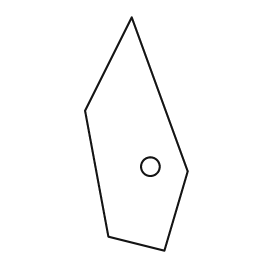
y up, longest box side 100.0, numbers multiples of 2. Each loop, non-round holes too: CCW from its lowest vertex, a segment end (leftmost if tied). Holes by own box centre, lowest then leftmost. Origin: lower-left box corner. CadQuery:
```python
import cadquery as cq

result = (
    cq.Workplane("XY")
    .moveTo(34.0, 0.0)
    .lineTo(44.0, 34.0)
    .lineTo(20.0, 100.0)
    .lineTo(0.0, 60.0)
    .lineTo(10.0, 6.0)
    .close()
    .moveTo(28.0, 36.0)
    .circle(4.0)
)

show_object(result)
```